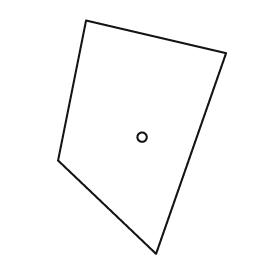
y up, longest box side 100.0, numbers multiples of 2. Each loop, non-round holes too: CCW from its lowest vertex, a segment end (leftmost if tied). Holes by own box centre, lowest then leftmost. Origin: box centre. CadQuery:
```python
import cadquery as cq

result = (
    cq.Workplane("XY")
    .moveTo(6.0, -50.0)
    .lineTo(36.0, 36.0)
    .lineTo(-24.0, 50.0)
    .lineTo(-36.0, -10.0)
    .close()
    .moveTo(0.0, 0.0)
    .circle(2.0)
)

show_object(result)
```